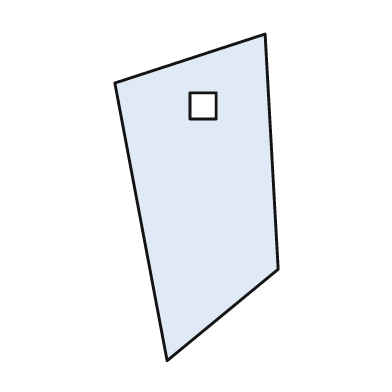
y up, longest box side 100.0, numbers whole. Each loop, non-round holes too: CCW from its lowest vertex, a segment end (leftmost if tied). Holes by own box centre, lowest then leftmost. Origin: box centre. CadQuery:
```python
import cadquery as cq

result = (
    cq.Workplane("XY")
    .moveTo(-9.0, -50.0)
    .lineTo(25.0, -22.0)
    .lineTo(21.0, 50.0)
    .lineTo(-25.0, 35.0)
    .close()
    .moveTo(-2.0, 24.0)
    .lineTo(6.0, 24.0)
    .lineTo(6.0, 32.0)
    .lineTo(-2.0, 32.0)
    .close()
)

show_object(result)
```